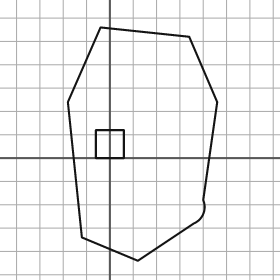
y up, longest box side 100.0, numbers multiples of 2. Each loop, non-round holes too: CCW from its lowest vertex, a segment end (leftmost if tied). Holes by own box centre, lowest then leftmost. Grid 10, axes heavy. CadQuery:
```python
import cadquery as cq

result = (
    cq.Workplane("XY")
    .moveTo(12.0, -44.0)
    .lineTo(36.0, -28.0)
    .threePointArc((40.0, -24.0), (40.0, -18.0))
    .lineTo(46.0, 24.0)
    .lineTo(34.0, 52.0)
    .lineTo(-4.0, 56.0)
    .lineTo(-18.0, 24.0)
    .lineTo(-12.0, -34.0)
    .close()
    .moveTo(-6.0, 0.0)
    .lineTo(6.0, 0.0)
    .lineTo(6.0, 12.0)
    .lineTo(-6.0, 12.0)
    .close()
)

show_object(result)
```